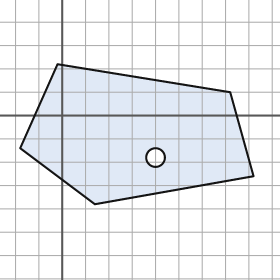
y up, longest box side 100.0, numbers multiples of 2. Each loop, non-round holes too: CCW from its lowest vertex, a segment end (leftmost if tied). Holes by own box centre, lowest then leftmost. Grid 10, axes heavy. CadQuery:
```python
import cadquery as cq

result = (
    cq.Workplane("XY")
    .moveTo(14.0, -38.0)
    .lineTo(82.0, -26.0)
    .lineTo(72.0, 10.0)
    .lineTo(-2.0, 22.0)
    .lineTo(-18.0, -14.0)
    .close()
    .moveTo(40.0, -18.0)
    .circle(4.0)
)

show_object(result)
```